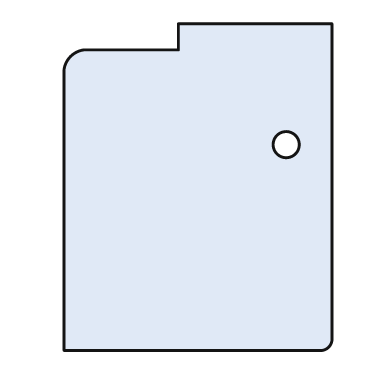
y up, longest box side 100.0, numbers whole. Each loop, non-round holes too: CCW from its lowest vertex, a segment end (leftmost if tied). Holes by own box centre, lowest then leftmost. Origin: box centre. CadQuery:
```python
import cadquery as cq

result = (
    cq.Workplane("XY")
    .moveTo(-41.0, -50.0)
    .lineTo(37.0, -50.0)
    .threePointArc((40.0, -49.0), (41.0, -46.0))
    .lineTo(41.0, 50.0)
    .lineTo(-6.0, 50.0)
    .lineTo(-6.0, 42.0)
    .lineTo(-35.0, 42.0)
    .threePointArc((-39.0, 40.0), (-41.0, 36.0))
    .close()
    .moveTo(27.0, 13.0)
    .circle(4.0)
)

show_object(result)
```